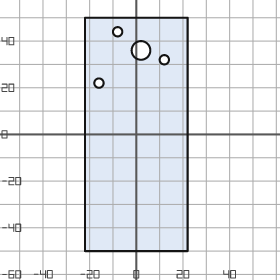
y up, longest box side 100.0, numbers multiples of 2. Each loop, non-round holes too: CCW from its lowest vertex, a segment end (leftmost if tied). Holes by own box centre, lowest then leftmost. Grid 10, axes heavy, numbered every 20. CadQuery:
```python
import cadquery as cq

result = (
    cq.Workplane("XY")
    .moveTo(-22.0, -50.0)
    .lineTo(22.0, -50.0)
    .lineTo(22.0, 50.0)
    .lineTo(-22.0, 50.0)
    .close()
    .moveTo(-16.0, 22.0)
    .circle(2.0)
    .moveTo(12.0, 32.0)
    .circle(2.0)
    .moveTo(2.0, 36.0)
    .circle(4.0)
    .moveTo(-8.0, 44.0)
    .circle(2.0)
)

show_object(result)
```